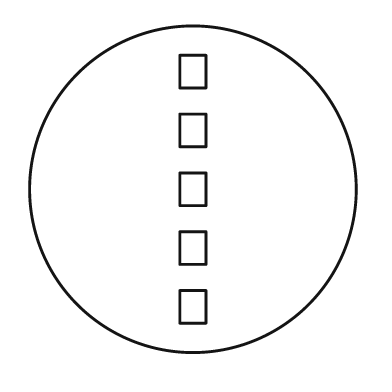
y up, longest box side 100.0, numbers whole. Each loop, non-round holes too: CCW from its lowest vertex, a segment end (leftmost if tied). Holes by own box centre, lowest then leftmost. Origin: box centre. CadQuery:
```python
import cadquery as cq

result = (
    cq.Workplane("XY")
    .moveTo(0.0, 0.0)
    .circle(50.0)
    .moveTo(-4.0, -41.0)
    .lineTo(4.0, -41.0)
    .lineTo(4.0, -31.0)
    .lineTo(-4.0, -31.0)
    .close()
    .moveTo(-4.0, -23.0)
    .lineTo(4.0, -23.0)
    .lineTo(4.0, -13.0)
    .lineTo(-4.0, -13.0)
    .close()
    .moveTo(-4.0, -5.0)
    .lineTo(4.0, -5.0)
    .lineTo(4.0, 5.0)
    .lineTo(-4.0, 5.0)
    .close()
    .moveTo(-4.0, 13.0)
    .lineTo(4.0, 13.0)
    .lineTo(4.0, 23.0)
    .lineTo(-4.0, 23.0)
    .close()
    .moveTo(-4.0, 31.0)
    .lineTo(4.0, 31.0)
    .lineTo(4.0, 41.0)
    .lineTo(-4.0, 41.0)
    .close()
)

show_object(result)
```